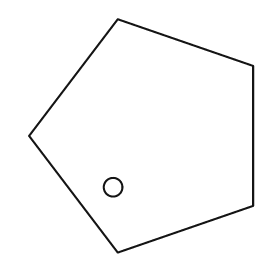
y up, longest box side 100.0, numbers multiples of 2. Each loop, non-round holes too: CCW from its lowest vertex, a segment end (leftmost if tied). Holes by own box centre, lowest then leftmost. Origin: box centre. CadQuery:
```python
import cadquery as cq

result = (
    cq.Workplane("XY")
    .moveTo(-10.0, -50.0)
    .lineTo(48.0, -30.0)
    .lineTo(48.0, 30.0)
    .lineTo(-10.0, 50.0)
    .lineTo(-48.0, 0.0)
    .close()
    .moveTo(-12.0, -22.0)
    .circle(4.0)
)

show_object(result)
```